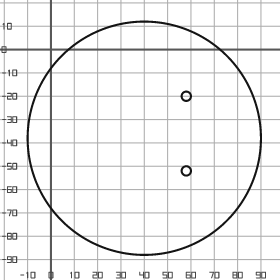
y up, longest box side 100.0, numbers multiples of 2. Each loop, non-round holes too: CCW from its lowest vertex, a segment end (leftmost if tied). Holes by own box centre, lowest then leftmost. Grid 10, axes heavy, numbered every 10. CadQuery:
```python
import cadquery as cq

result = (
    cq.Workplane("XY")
    .moveTo(40.0, -38.0)
    .circle(50.0)
    .moveTo(58.0, -52.0)
    .circle(2.0)
    .moveTo(58.0, -20.0)
    .circle(2.0)
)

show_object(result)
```